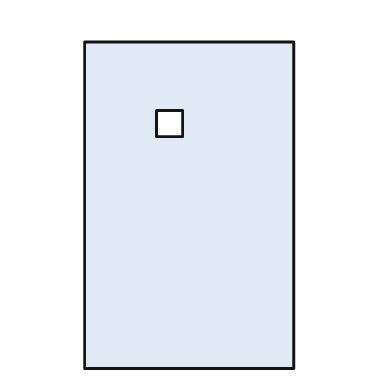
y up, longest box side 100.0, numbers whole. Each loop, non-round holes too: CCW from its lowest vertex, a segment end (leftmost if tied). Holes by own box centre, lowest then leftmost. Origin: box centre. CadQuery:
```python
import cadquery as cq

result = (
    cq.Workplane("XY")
    .moveTo(-32.0, -50.0)
    .lineTo(32.0, -50.0)
    .lineTo(32.0, 50.0)
    .lineTo(-32.0, 50.0)
    .close()
    .moveTo(-10.0, 21.0)
    .lineTo(-2.0, 21.0)
    .lineTo(-2.0, 29.0)
    .lineTo(-10.0, 29.0)
    .close()
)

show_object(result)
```